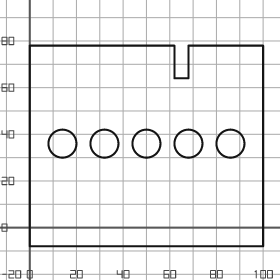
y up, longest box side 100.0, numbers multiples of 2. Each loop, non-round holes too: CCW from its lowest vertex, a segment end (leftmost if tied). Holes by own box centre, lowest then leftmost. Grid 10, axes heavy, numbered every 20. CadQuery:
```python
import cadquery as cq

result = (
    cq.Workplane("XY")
    .moveTo(0.0, -8.0)
    .lineTo(100.0, -8.0)
    .lineTo(100.0, 78.0)
    .lineTo(68.0, 78.0)
    .lineTo(68.0, 64.0)
    .lineTo(62.0, 64.0)
    .lineTo(62.0, 78.0)
    .lineTo(0.0, 78.0)
    .close()
    .moveTo(14.0, 36.0)
    .circle(6.0)
    .moveTo(32.0, 36.0)
    .circle(6.0)
    .moveTo(50.0, 36.0)
    .circle(6.0)
    .moveTo(68.0, 36.0)
    .circle(6.0)
    .moveTo(86.0, 36.0)
    .circle(6.0)
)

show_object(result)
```